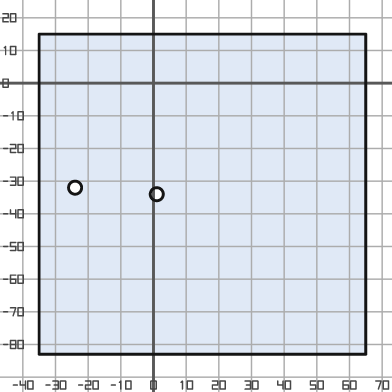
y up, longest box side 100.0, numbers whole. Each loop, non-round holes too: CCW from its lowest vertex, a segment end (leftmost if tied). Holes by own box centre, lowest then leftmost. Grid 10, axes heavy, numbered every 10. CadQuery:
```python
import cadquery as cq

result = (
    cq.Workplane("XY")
    .moveTo(-35.0, -83.0)
    .lineTo(65.0, -83.0)
    .lineTo(65.0, 15.0)
    .lineTo(-35.0, 15.0)
    .close()
    .moveTo(1.0, -34.0)
    .circle(2.0)
    .moveTo(-24.0, -32.0)
    .circle(2.0)
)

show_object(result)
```